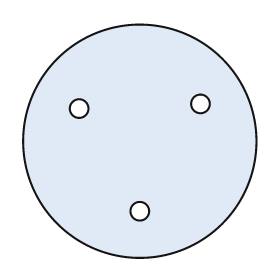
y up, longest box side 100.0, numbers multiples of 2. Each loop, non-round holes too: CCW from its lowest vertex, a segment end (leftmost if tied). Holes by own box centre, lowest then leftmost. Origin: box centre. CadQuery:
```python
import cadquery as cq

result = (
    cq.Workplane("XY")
    .moveTo(0.0, 0.0)
    .circle(50.0)
    .moveTo(0.0, -30.0)
    .circle(4.0)
    .moveTo(-26.0, 14.0)
    .circle(4.0)
    .moveTo(26.0, 16.0)
    .circle(4.0)
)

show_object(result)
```